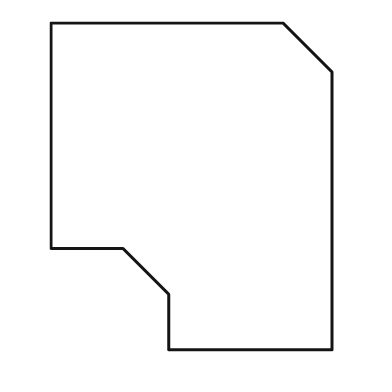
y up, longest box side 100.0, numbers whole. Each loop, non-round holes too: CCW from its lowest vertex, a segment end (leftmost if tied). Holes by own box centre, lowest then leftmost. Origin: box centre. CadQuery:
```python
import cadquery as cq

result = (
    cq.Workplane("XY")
    .moveTo(-7.0, -50.0)
    .lineTo(43.0, -50.0)
    .lineTo(43.0, 35.0)
    .lineTo(28.0, 50.0)
    .lineTo(-43.0, 50.0)
    .lineTo(-43.0, -19.0)
    .lineTo(-21.0, -19.0)
    .lineTo(-7.0, -33.0)
    .close()
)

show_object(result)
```